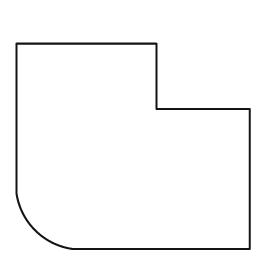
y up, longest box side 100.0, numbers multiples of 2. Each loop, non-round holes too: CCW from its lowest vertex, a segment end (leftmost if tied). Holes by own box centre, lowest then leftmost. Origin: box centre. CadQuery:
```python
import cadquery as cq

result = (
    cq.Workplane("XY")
    .moveTo(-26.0, -44.0)
    .lineTo(50.0, -44.0)
    .lineTo(50.0, 16.0)
    .lineTo(10.0, 16.0)
    .lineTo(10.0, 44.0)
    .lineTo(-50.0, 44.0)
    .lineTo(-50.0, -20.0)
    .threePointArc((-42.0, -36.0), (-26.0, -44.0))
    .close()
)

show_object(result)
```